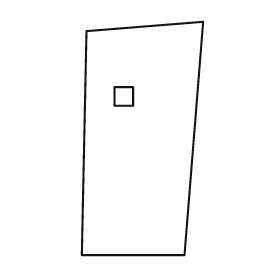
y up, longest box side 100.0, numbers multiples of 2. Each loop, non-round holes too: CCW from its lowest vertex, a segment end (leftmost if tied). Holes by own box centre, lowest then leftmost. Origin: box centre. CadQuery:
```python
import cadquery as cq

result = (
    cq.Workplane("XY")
    .moveTo(-26.0, -50.0)
    .lineTo(18.0, -50.0)
    .lineTo(26.0, 50.0)
    .lineTo(-24.0, 46.0)
    .close()
    .moveTo(-12.0, 14.0)
    .lineTo(-4.0, 14.0)
    .lineTo(-4.0, 22.0)
    .lineTo(-12.0, 22.0)
    .close()
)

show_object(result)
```